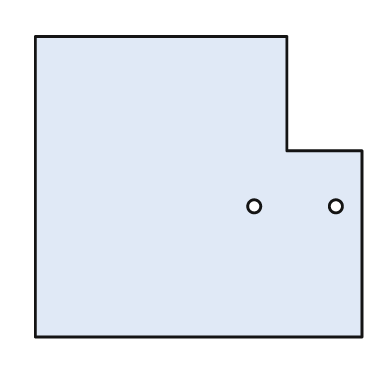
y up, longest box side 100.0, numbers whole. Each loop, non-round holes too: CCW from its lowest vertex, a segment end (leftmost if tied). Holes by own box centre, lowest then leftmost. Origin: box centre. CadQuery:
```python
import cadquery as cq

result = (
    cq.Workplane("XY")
    .moveTo(-50.0, -46.0)
    .lineTo(50.0, -46.0)
    .lineTo(50.0, 11.0)
    .lineTo(27.0, 11.0)
    .lineTo(27.0, 46.0)
    .lineTo(-50.0, 46.0)
    .close()
    .moveTo(17.0, -6.0)
    .circle(2.0)
    .moveTo(42.0, -6.0)
    .circle(2.0)
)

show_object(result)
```